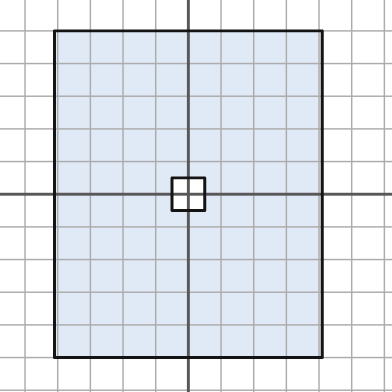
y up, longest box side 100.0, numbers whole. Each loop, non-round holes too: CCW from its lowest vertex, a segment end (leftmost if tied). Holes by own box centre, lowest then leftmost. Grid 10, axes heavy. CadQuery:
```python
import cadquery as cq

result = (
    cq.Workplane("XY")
    .moveTo(-41.0, -50.0)
    .lineTo(41.0, -50.0)
    .lineTo(41.0, 50.0)
    .lineTo(-41.0, 50.0)
    .close()
    .moveTo(-5.0, -5.0)
    .lineTo(5.0, -5.0)
    .lineTo(5.0, 5.0)
    .lineTo(-5.0, 5.0)
    .close()
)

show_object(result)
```